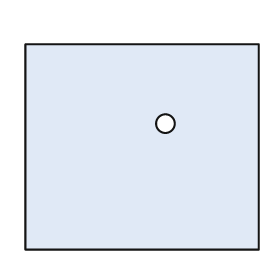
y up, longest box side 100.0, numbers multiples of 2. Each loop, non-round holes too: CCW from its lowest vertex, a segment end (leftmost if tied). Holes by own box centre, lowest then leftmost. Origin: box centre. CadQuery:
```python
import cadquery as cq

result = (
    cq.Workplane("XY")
    .moveTo(-50.0, -44.0)
    .lineTo(50.0, -44.0)
    .lineTo(50.0, 44.0)
    .lineTo(-50.0, 44.0)
    .close()
    .moveTo(10.0, 10.0)
    .circle(4.0)
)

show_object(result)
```